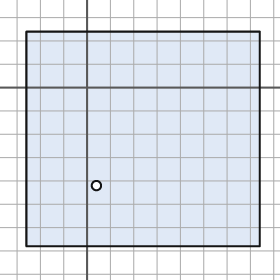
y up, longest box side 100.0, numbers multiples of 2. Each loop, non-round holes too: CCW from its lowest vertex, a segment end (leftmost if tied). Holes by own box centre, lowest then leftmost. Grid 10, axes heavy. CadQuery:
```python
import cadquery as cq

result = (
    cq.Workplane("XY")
    .moveTo(-26.0, -68.0)
    .lineTo(74.0, -68.0)
    .lineTo(74.0, 24.0)
    .lineTo(-26.0, 24.0)
    .close()
    .moveTo(4.0, -42.0)
    .circle(2.0)
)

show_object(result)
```